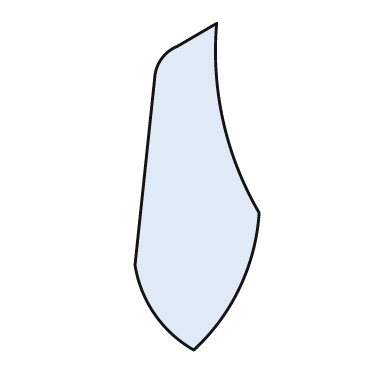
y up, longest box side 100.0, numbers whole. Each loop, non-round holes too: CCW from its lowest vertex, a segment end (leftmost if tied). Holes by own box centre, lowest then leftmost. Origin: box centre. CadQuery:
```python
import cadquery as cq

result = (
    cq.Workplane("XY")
    .moveTo(-1.0, -50.0)
    .threePointArc((13.0, -31.0), (19.0, -8.0))
    .threePointArc((8.0, 20.0), (6.0, 50.0))
    .lineTo(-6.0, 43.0)
    .threePointArc((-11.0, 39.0), (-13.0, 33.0))
    .lineTo(-19.0, -24.0)
    .threePointArc((-13.0, -39.0), (-1.0, -50.0))
    .close()
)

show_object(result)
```